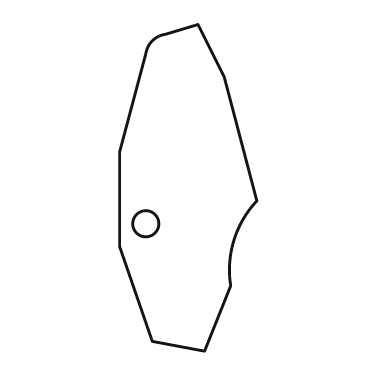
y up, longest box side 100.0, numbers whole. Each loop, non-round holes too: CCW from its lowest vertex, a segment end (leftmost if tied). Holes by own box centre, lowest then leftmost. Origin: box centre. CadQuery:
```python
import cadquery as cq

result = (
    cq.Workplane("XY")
    .moveTo(5.0, -50.0)
    .lineTo(13.0, -30.0)
    .threePointArc((14.0, -16.0), (21.0, -4.0))
    .lineTo(11.0, 34.0)
    .lineTo(3.0, 50.0)
    .lineTo(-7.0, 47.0)
    .threePointArc((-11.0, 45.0), (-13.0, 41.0))
    .lineTo(-21.0, 11.0)
    .lineTo(-21.0, -18.0)
    .lineTo(-11.0, -47.0)
    .close()
    .moveTo(-13.0, -11.0)
    .circle(4.0)
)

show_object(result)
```